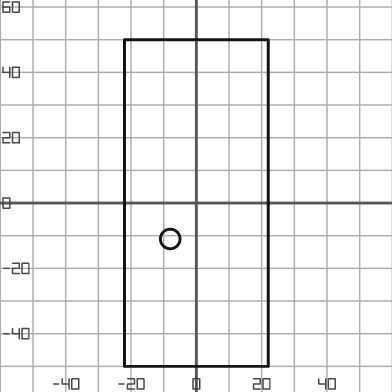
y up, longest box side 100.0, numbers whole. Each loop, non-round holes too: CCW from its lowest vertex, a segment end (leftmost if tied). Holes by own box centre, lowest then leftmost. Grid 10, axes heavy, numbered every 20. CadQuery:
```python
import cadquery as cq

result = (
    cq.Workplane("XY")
    .moveTo(-22.0, -50.0)
    .lineTo(22.0, -50.0)
    .lineTo(22.0, 50.0)
    .lineTo(-22.0, 50.0)
    .close()
    .moveTo(-8.0, -11.0)
    .circle(3.0)
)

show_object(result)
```